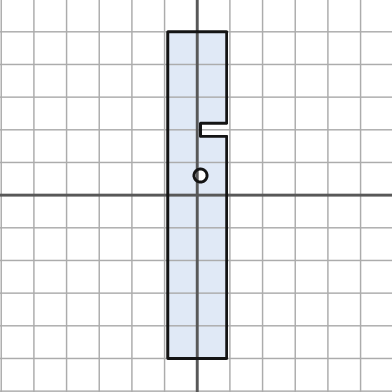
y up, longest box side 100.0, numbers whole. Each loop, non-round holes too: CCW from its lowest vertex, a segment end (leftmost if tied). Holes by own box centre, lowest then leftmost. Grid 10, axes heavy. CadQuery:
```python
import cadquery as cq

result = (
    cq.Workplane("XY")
    .moveTo(-9.0, -50.0)
    .lineTo(9.0, -50.0)
    .lineTo(9.0, 18.0)
    .lineTo(1.0, 18.0)
    .lineTo(1.0, 22.0)
    .lineTo(9.0, 22.0)
    .lineTo(9.0, 50.0)
    .lineTo(-9.0, 50.0)
    .close()
    .moveTo(1.0, 6.0)
    .circle(2.0)
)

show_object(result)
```